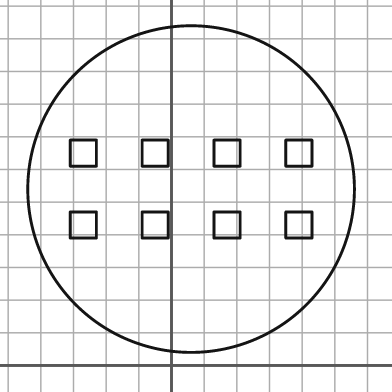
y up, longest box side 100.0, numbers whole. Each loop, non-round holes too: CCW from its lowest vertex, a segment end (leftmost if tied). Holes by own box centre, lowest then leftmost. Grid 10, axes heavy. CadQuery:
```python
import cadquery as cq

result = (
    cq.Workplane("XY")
    .moveTo(6.0, 54.0)
    .circle(50.0)
    .moveTo(-31.0, 39.0)
    .lineTo(-23.0, 39.0)
    .lineTo(-23.0, 47.0)
    .lineTo(-31.0, 47.0)
    .close()
    .moveTo(-9.0, 39.0)
    .lineTo(-1.0, 39.0)
    .lineTo(-1.0, 47.0)
    .lineTo(-9.0, 47.0)
    .close()
    .moveTo(13.0, 39.0)
    .lineTo(21.0, 39.0)
    .lineTo(21.0, 47.0)
    .lineTo(13.0, 47.0)
    .close()
    .moveTo(35.0, 39.0)
    .lineTo(43.0, 39.0)
    .lineTo(43.0, 47.0)
    .lineTo(35.0, 47.0)
    .close()
    .moveTo(-31.0, 61.0)
    .lineTo(-23.0, 61.0)
    .lineTo(-23.0, 69.0)
    .lineTo(-31.0, 69.0)
    .close()
    .moveTo(-9.0, 61.0)
    .lineTo(-1.0, 61.0)
    .lineTo(-1.0, 69.0)
    .lineTo(-9.0, 69.0)
    .close()
    .moveTo(13.0, 61.0)
    .lineTo(21.0, 61.0)
    .lineTo(21.0, 69.0)
    .lineTo(13.0, 69.0)
    .close()
    .moveTo(35.0, 61.0)
    .lineTo(43.0, 61.0)
    .lineTo(43.0, 69.0)
    .lineTo(35.0, 69.0)
    .close()
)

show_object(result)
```